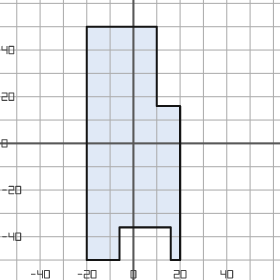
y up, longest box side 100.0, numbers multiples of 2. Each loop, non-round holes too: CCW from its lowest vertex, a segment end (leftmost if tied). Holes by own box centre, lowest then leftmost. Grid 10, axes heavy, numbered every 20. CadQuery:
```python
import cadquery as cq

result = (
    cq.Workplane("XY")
    .moveTo(-20.0, -50.0)
    .lineTo(-6.0, -50.0)
    .lineTo(-6.0, -36.0)
    .lineTo(16.0, -36.0)
    .lineTo(16.0, -50.0)
    .lineTo(20.0, -50.0)
    .lineTo(20.0, 16.0)
    .lineTo(10.0, 16.0)
    .lineTo(10.0, 50.0)
    .lineTo(-20.0, 50.0)
    .close()
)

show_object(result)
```